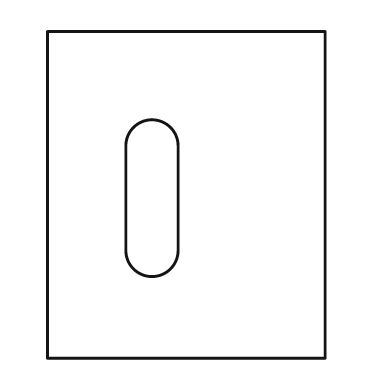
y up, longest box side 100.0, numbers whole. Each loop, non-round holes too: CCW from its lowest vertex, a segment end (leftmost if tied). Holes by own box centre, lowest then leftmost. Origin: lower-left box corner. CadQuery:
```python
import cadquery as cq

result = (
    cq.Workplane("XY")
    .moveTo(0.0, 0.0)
    .lineTo(85.0, 0.0)
    .lineTo(85.0, 100.0)
    .lineTo(0.0, 100.0)
    .close()
    .moveTo(24.0, 33.0)
    .threePointArc((32.0, 25.0), (40.0, 33.0))
    .lineTo(40.0, 65.0)
    .threePointArc((32.0, 73.0), (24.0, 65.0))
    .close()
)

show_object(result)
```